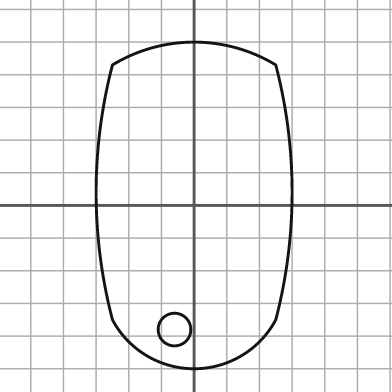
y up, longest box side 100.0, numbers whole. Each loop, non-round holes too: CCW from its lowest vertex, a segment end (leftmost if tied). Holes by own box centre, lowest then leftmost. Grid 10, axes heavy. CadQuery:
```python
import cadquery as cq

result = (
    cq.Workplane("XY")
    .moveTo(-25.0, -35.0)
    .threePointArc((0.0, -50.0), (25.0, -35.0))
    .threePointArc((30.0, 4.0), (25.0, 43.0))
    .threePointArc((0.0, 50.0), (-25.0, 43.0))
    .threePointArc((-30.0, 4.0), (-25.0, -35.0))
    .close()
    .moveTo(-6.0, -38.0)
    .circle(5.0)
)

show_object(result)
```